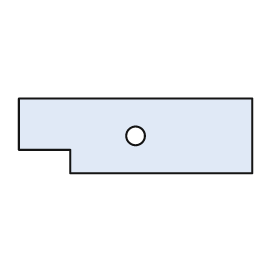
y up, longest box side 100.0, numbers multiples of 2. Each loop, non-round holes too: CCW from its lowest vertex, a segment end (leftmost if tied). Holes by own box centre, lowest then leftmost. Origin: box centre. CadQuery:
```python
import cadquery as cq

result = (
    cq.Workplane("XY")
    .moveTo(-28.0, -16.0)
    .lineTo(50.0, -16.0)
    .lineTo(50.0, 16.0)
    .lineTo(-50.0, 16.0)
    .lineTo(-50.0, -6.0)
    .lineTo(-28.0, -6.0)
    .close()
    .moveTo(0.0, 0.0)
    .circle(4.0)
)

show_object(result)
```